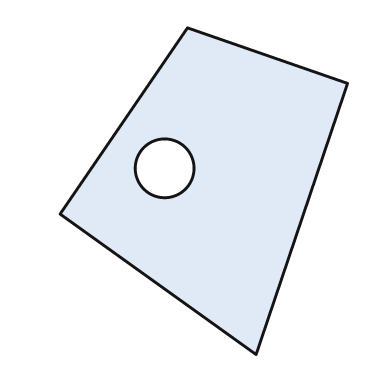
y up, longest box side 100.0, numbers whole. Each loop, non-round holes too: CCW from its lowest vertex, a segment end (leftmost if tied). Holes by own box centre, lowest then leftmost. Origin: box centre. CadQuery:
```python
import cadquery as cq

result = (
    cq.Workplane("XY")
    .moveTo(16.0, -50.0)
    .lineTo(44.0, 33.0)
    .lineTo(-5.0, 50.0)
    .lineTo(-44.0, -7.0)
    .close()
    .moveTo(-12.0, 7.0)
    .circle(9.0)
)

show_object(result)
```